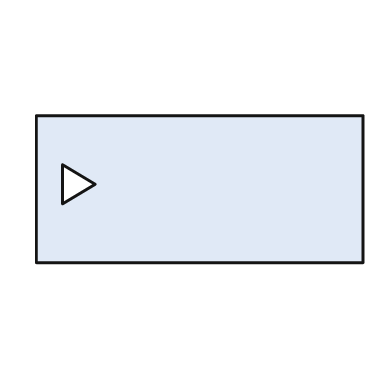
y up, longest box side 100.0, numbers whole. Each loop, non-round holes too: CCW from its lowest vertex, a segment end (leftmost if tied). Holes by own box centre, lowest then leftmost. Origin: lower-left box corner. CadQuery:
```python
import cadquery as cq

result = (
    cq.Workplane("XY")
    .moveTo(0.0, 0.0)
    .lineTo(100.0, 0.0)
    .lineTo(100.0, 45.0)
    .lineTo(0.0, 45.0)
    .close()
    .moveTo(8.0, 18.0)
    .lineTo(18.0, 24.0)
    .lineTo(8.0, 30.0)
    .close()
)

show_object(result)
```